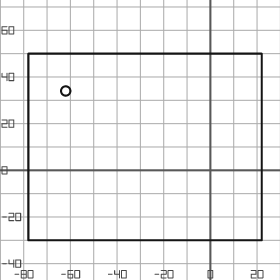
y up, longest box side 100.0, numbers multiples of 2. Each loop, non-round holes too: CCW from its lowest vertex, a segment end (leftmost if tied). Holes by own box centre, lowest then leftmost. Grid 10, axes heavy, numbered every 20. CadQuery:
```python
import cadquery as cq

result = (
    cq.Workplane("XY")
    .moveTo(-78.0, -30.0)
    .lineTo(22.0, -30.0)
    .lineTo(22.0, 50.0)
    .lineTo(-78.0, 50.0)
    .close()
    .moveTo(-62.0, 34.0)
    .circle(2.0)
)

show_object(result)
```